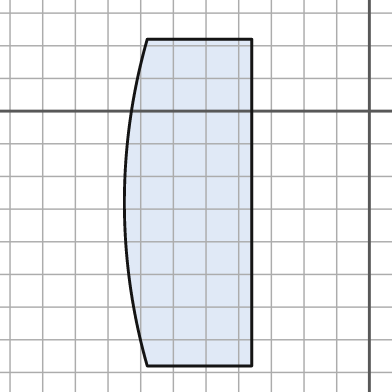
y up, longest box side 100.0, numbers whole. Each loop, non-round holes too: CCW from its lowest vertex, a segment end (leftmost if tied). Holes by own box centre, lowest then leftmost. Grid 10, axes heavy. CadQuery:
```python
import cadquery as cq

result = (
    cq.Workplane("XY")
    .moveTo(-68.0, -78.0)
    .lineTo(-36.0, -78.0)
    .lineTo(-36.0, 22.0)
    .lineTo(-68.0, 22.0)
    .threePointArc((-75.0, -28.0), (-68.0, -78.0))
    .close()
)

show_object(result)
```